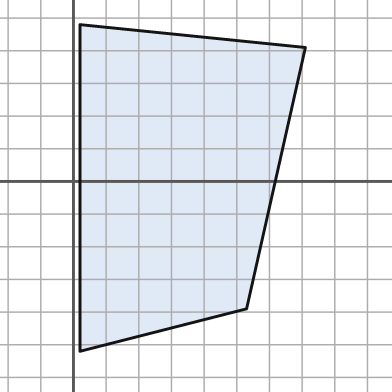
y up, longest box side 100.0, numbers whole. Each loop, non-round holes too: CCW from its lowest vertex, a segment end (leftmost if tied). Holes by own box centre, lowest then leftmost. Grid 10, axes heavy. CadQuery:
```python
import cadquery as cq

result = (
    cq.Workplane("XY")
    .moveTo(2.0, -52.0)
    .lineTo(53.0, -39.0)
    .lineTo(71.0, 41.0)
    .lineTo(2.0, 48.0)
    .close()
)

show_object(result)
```